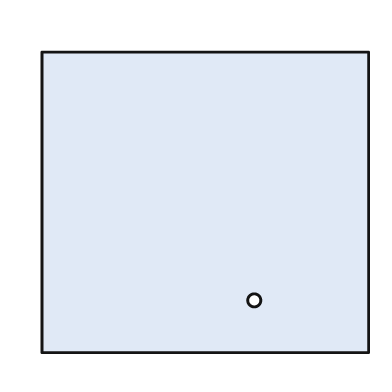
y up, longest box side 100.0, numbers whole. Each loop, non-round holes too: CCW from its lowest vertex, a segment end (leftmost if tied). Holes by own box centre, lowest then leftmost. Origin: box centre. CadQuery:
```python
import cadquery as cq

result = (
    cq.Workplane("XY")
    .moveTo(-50.0, -46.0)
    .lineTo(50.0, -46.0)
    .lineTo(50.0, 46.0)
    .lineTo(-50.0, 46.0)
    .close()
    .moveTo(15.0, -30.0)
    .circle(2.0)
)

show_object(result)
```